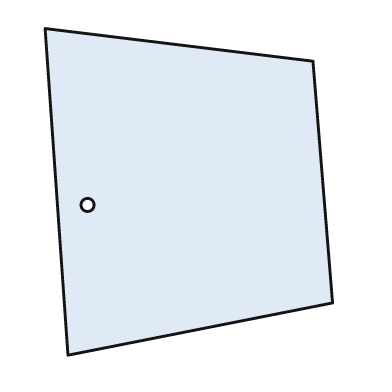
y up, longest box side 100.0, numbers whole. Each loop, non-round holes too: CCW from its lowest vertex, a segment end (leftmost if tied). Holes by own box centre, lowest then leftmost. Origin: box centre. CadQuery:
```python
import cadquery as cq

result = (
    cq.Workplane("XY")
    .moveTo(-37.0, -50.0)
    .lineTo(44.0, -34.0)
    .lineTo(38.0, 40.0)
    .lineTo(-44.0, 50.0)
    .close()
    .moveTo(-31.0, -4.0)
    .circle(2.0)
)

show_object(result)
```